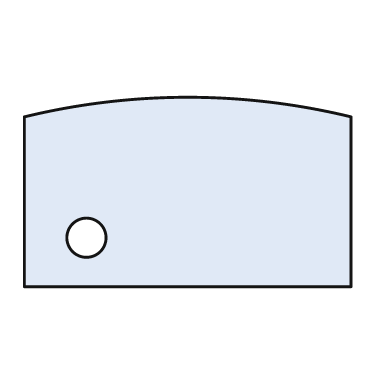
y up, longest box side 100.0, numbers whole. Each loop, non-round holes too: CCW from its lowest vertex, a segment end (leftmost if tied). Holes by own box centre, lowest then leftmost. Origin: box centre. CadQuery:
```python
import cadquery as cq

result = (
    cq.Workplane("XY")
    .moveTo(-50.0, -29.0)
    .lineTo(50.0, -29.0)
    .lineTo(50.0, 23.0)
    .threePointArc((0.0, 29.0), (-50.0, 23.0))
    .close()
    .moveTo(-31.0, -14.0)
    .circle(6.0)
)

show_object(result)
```